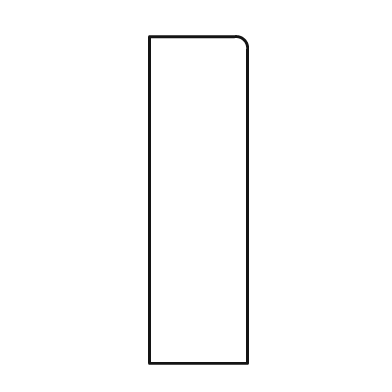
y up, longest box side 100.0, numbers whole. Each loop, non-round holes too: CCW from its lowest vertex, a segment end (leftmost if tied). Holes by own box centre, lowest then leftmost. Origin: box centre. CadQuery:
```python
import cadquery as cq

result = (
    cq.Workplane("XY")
    .moveTo(-15.0, -50.0)
    .lineTo(15.0, -50.0)
    .lineTo(15.0, 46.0)
    .threePointArc((14.0, 49.0), (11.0, 50.0))
    .lineTo(-15.0, 50.0)
    .close()
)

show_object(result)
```